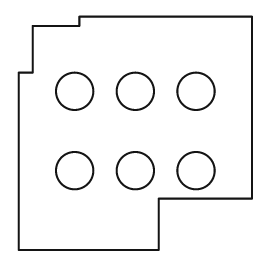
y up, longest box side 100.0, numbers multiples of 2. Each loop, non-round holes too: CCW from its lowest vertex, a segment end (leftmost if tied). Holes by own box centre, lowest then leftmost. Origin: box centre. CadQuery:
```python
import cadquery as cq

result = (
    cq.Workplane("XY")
    .moveTo(-50.0, -50.0)
    .lineTo(10.0, -50.0)
    .lineTo(10.0, -28.0)
    .lineTo(50.0, -28.0)
    .lineTo(50.0, 50.0)
    .lineTo(-24.0, 50.0)
    .lineTo(-24.0, 46.0)
    .lineTo(-44.0, 46.0)
    .lineTo(-44.0, 26.0)
    .lineTo(-50.0, 26.0)
    .close()
    .moveTo(-26.0, -16.0)
    .circle(8.0)
    .moveTo(0.0, -16.0)
    .circle(8.0)
    .moveTo(26.0, -16.0)
    .circle(8.0)
    .moveTo(-26.0, 18.0)
    .circle(8.0)
    .moveTo(0.0, 18.0)
    .circle(8.0)
    .moveTo(26.0, 18.0)
    .circle(8.0)
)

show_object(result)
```